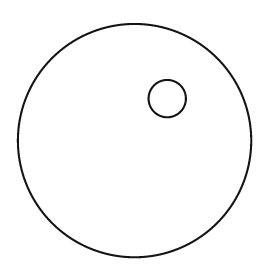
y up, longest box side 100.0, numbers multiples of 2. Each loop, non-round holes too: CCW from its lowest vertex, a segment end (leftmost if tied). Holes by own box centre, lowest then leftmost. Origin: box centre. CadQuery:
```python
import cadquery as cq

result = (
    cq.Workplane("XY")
    .moveTo(0.0, 0.0)
    .circle(50.0)
    .moveTo(14.0, 18.0)
    .circle(8.0)
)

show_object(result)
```